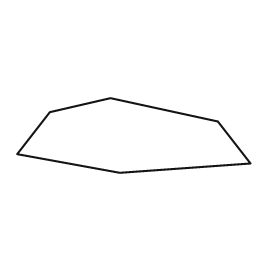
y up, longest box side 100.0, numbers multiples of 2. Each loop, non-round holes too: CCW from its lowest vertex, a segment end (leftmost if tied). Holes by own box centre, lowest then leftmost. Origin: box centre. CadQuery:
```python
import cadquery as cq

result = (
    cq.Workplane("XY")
    .moveTo(-6.0, -16.0)
    .lineTo(50.0, -12.0)
    .lineTo(36.0, 6.0)
    .lineTo(-10.0, 16.0)
    .lineTo(-36.0, 10.0)
    .lineTo(-50.0, -8.0)
    .close()
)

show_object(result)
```